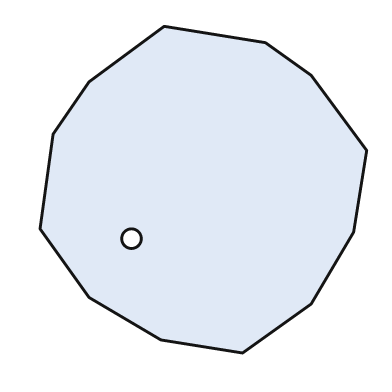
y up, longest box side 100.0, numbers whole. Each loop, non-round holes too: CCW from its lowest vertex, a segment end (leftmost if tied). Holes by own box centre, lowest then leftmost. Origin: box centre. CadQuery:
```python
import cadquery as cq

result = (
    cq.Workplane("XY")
    .moveTo(12.0, -50.0)
    .lineTo(33.0, -35.0)
    .lineTo(46.0, -13.0)
    .lineTo(50.0, 12.0)
    .lineTo(33.0, 35.0)
    .lineTo(19.0, 45.0)
    .lineTo(-12.0, 50.0)
    .lineTo(-35.0, 33.0)
    .lineTo(-46.0, 17.0)
    .lineTo(-50.0, -12.0)
    .lineTo(-35.0, -33.0)
    .lineTo(-13.0, -46.0)
    .close()
    .moveTo(-22.0, -15.0)
    .circle(3.0)
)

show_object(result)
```